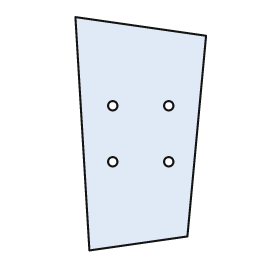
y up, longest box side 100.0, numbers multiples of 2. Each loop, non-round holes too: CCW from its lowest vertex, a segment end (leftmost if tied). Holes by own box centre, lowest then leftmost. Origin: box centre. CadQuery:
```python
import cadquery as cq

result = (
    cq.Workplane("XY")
    .moveTo(-22.0, -50.0)
    .lineTo(20.0, -44.0)
    .lineTo(28.0, 42.0)
    .lineTo(-28.0, 50.0)
    .close()
    .moveTo(-12.0, -12.0)
    .circle(2.0)
    .moveTo(12.0, -12.0)
    .circle(2.0)
    .moveTo(-12.0, 12.0)
    .circle(2.0)
    .moveTo(12.0, 12.0)
    .circle(2.0)
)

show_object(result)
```